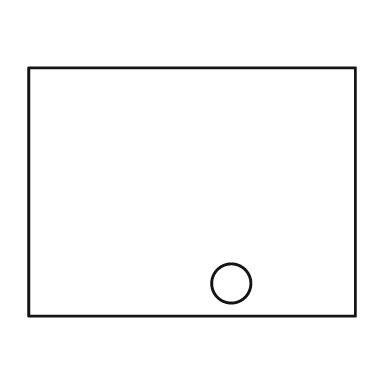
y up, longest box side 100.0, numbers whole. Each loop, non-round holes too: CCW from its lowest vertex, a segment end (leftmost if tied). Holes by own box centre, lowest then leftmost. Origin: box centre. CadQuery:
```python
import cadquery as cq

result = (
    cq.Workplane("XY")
    .moveTo(-50.0, -38.0)
    .lineTo(50.0, -38.0)
    .lineTo(50.0, 38.0)
    .lineTo(-50.0, 38.0)
    .close()
    .moveTo(12.0, -28.0)
    .circle(6.0)
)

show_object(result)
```